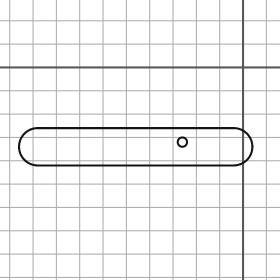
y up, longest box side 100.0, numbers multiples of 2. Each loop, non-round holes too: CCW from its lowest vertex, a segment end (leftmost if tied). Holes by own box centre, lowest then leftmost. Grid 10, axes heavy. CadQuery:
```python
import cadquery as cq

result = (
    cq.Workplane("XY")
    .moveTo(-88.0, -42.0)
    .lineTo(-4.0, -42.0)
    .threePointArc((4.0, -34.0), (-4.0, -26.0))
    .lineTo(-88.0, -26.0)
    .threePointArc((-96.0, -34.0), (-88.0, -42.0))
    .close()
    .moveTo(-26.0, -32.0)
    .circle(2.0)
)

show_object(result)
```